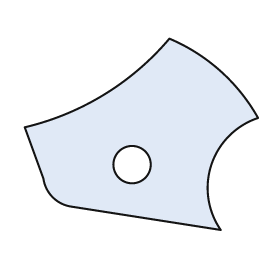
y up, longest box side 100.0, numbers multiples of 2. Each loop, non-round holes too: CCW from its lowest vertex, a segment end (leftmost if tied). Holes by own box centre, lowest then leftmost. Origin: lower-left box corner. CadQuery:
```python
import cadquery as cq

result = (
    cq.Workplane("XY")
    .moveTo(84.0, 0.0)
    .threePointArc((80.0, 28.0), (100.0, 48.0))
    .threePointArc((84.0, 68.0), (62.0, 82.0))
    .threePointArc((34.0, 58.0), (0.0, 44.0))
    .lineTo(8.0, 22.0)
    .threePointArc((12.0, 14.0), (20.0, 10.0))
    .close()
    .moveTo(46.0, 28.0)
    .circle(8.0)
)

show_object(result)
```